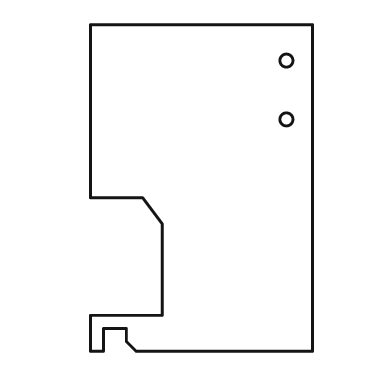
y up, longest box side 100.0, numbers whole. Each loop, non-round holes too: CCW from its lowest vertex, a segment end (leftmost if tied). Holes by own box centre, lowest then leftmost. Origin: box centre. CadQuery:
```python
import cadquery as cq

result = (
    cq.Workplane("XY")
    .moveTo(-34.0, -50.0)
    .lineTo(-30.0, -50.0)
    .lineTo(-30.0, -43.0)
    .lineTo(-23.0, -43.0)
    .lineTo(-23.0, -47.0)
    .lineTo(-20.0, -50.0)
    .lineTo(34.0, -50.0)
    .lineTo(34.0, 50.0)
    .lineTo(-34.0, 50.0)
    .lineTo(-34.0, -3.0)
    .lineTo(-18.0, -3.0)
    .lineTo(-12.0, -11.0)
    .lineTo(-12.0, -39.0)
    .lineTo(-34.0, -39.0)
    .close()
    .moveTo(26.0, 21.0)
    .circle(2.0)
    .moveTo(26.0, 39.0)
    .circle(2.0)
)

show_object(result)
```